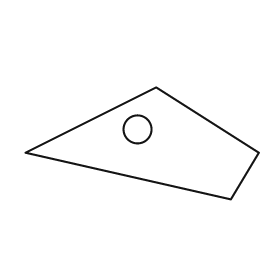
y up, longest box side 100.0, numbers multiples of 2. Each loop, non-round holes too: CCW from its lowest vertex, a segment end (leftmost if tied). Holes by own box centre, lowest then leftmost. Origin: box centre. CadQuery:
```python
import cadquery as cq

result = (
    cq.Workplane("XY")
    .moveTo(38.0, -24.0)
    .lineTo(50.0, -4.0)
    .lineTo(6.0, 24.0)
    .lineTo(-50.0, -4.0)
    .close()
    .moveTo(-2.0, 6.0)
    .circle(6.0)
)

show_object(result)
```